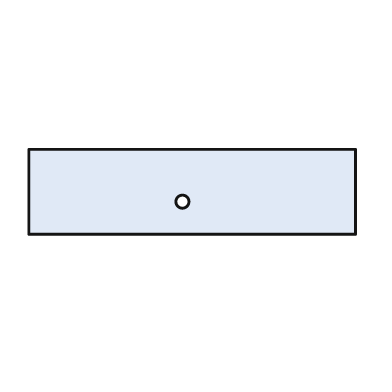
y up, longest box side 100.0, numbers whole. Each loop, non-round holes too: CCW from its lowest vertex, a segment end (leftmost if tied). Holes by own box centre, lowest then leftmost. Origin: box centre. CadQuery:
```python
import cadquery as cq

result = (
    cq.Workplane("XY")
    .moveTo(-50.0, -13.0)
    .lineTo(50.0, -13.0)
    .lineTo(50.0, 13.0)
    .lineTo(-50.0, 13.0)
    .close()
    .moveTo(-3.0, -3.0)
    .circle(2.0)
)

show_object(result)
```